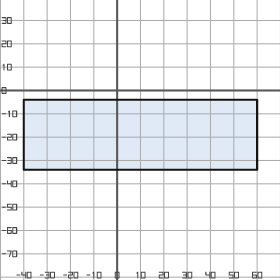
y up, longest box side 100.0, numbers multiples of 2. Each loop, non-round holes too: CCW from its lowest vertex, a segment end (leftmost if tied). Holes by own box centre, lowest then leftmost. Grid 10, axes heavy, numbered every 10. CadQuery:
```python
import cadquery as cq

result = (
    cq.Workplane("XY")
    .moveTo(-40.0, -34.0)
    .lineTo(60.0, -34.0)
    .lineTo(60.0, -4.0)
    .lineTo(-40.0, -4.0)
    .close()
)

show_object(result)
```